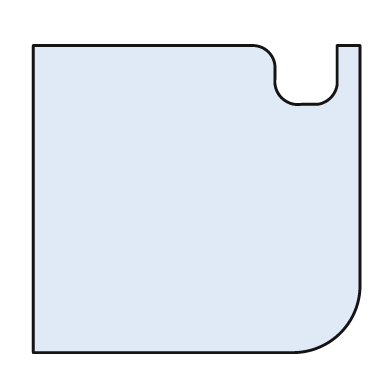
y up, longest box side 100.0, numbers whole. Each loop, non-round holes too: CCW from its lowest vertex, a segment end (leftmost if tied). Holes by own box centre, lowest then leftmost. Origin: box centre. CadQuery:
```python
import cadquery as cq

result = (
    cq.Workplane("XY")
    .moveTo(-50.0, -47.0)
    .lineTo(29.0, -47.0)
    .threePointArc((44.0, -41.0), (50.0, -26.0))
    .lineTo(50.0, 47.0)
    .lineTo(43.0, 47.0)
    .lineTo(43.0, 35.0)
    .threePointArc((41.0, 31.0), (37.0, 29.0))
    .lineTo(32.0, 29.0)
    .threePointArc((26.0, 31.0), (24.0, 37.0))
    .lineTo(24.0, 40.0)
    .threePointArc((22.0, 45.0), (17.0, 47.0))
    .lineTo(-50.0, 47.0)
    .close()
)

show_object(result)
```